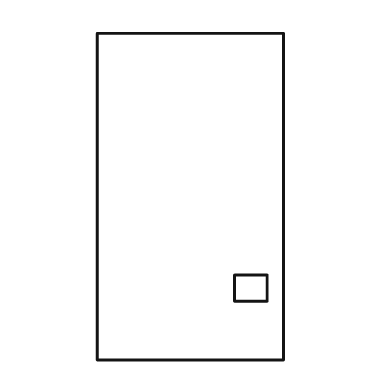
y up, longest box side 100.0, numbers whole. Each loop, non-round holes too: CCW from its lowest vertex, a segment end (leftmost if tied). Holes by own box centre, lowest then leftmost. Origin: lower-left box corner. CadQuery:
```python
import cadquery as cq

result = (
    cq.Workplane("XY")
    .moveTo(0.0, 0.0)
    .lineTo(57.0, 0.0)
    .lineTo(57.0, 100.0)
    .lineTo(0.0, 100.0)
    .close()
    .moveTo(42.0, 18.0)
    .lineTo(52.0, 18.0)
    .lineTo(52.0, 26.0)
    .lineTo(42.0, 26.0)
    .close()
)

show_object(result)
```